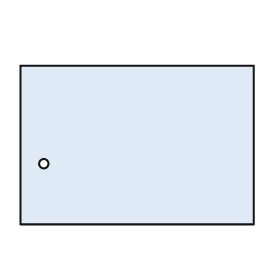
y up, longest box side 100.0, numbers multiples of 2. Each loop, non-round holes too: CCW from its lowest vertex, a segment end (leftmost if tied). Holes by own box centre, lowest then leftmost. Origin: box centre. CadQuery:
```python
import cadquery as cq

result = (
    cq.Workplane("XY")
    .moveTo(-50.0, -34.0)
    .lineTo(50.0, -34.0)
    .lineTo(50.0, 34.0)
    .lineTo(-50.0, 34.0)
    .close()
    .moveTo(-40.0, -8.0)
    .circle(2.0)
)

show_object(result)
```